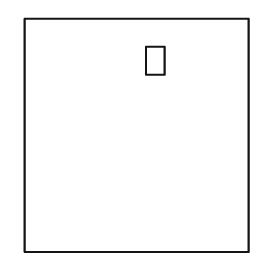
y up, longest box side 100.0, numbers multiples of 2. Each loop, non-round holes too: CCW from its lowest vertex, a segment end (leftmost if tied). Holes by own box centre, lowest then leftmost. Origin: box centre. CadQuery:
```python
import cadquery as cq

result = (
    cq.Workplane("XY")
    .moveTo(-48.0, -50.0)
    .lineTo(48.0, -50.0)
    .lineTo(48.0, 50.0)
    .lineTo(-48.0, 50.0)
    .close()
    .moveTo(4.0, 26.0)
    .lineTo(12.0, 26.0)
    .lineTo(12.0, 38.0)
    .lineTo(4.0, 38.0)
    .close()
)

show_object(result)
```